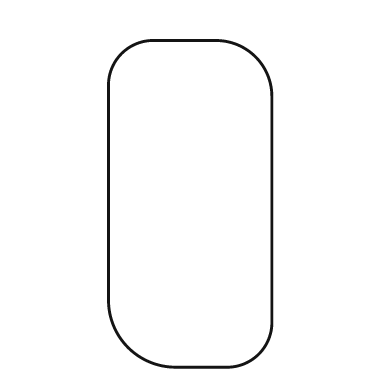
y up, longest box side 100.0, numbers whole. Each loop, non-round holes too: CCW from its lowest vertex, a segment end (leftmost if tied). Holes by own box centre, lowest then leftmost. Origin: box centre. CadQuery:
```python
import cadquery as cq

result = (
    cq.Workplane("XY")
    .moveTo(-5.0, -50.0)
    .lineTo(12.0, -50.0)
    .threePointArc((21.0, -46.0), (25.0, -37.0))
    .lineTo(25.0, 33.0)
    .threePointArc((20.0, 45.0), (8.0, 50.0))
    .lineTo(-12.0, 50.0)
    .threePointArc((-21.0, 46.0), (-25.0, 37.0))
    .lineTo(-25.0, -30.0)
    .threePointArc((-19.0, -44.0), (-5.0, -50.0))
    .close()
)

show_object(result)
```